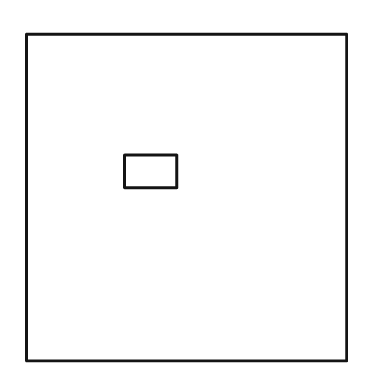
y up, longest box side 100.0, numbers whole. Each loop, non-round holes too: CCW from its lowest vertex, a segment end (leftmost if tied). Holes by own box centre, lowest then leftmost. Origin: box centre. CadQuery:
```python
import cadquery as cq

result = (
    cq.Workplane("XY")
    .moveTo(-49.0, -50.0)
    .lineTo(49.0, -50.0)
    .lineTo(49.0, 50.0)
    .lineTo(-49.0, 50.0)
    .close()
    .moveTo(-19.0, 3.0)
    .lineTo(-3.0, 3.0)
    .lineTo(-3.0, 13.0)
    .lineTo(-19.0, 13.0)
    .close()
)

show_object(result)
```